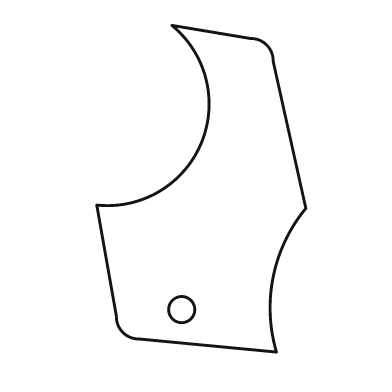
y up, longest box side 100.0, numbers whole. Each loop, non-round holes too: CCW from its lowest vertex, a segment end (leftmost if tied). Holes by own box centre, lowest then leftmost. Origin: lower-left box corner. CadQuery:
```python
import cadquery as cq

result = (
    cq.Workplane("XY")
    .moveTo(55.0, 0.0)
    .threePointArc((54.0, 23.0), (64.0, 44.0))
    .lineTo(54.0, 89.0)
    .threePointArc((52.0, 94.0), (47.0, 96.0))
    .lineTo(23.0, 100.0)
    .threePointArc((32.0, 64.0), (0.0, 45.0))
    .lineTo(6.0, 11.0)
    .threePointArc((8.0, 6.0), (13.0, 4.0))
    .close()
    .moveTo(26.0, 13.0)
    .circle(4.0)
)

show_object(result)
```